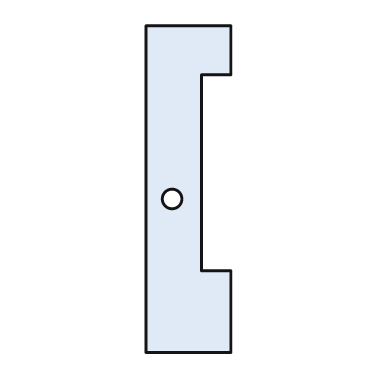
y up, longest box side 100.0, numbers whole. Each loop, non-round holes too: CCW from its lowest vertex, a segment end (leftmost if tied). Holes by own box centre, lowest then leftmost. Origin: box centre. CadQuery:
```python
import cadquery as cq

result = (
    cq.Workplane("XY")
    .moveTo(-13.0, -50.0)
    .lineTo(13.0, -50.0)
    .lineTo(13.0, -25.0)
    .lineTo(4.0, -25.0)
    .lineTo(4.0, 35.0)
    .lineTo(13.0, 35.0)
    .lineTo(13.0, 50.0)
    .lineTo(-13.0, 50.0)
    .close()
    .moveTo(-5.0, -3.0)
    .circle(3.0)
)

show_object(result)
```